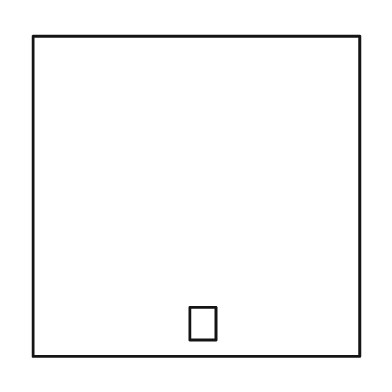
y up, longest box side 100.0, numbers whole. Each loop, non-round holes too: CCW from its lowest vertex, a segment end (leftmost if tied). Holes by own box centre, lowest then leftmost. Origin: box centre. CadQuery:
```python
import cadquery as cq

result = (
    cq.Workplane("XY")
    .moveTo(-50.0, -49.0)
    .lineTo(50.0, -49.0)
    .lineTo(50.0, 49.0)
    .lineTo(-50.0, 49.0)
    .close()
    .moveTo(-2.0, -44.0)
    .lineTo(6.0, -44.0)
    .lineTo(6.0, -34.0)
    .lineTo(-2.0, -34.0)
    .close()
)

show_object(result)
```